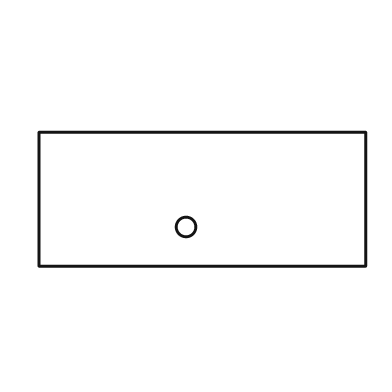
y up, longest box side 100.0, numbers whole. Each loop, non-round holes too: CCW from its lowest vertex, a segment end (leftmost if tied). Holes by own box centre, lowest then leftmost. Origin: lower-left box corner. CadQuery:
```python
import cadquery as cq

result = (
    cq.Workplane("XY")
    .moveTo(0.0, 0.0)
    .lineTo(100.0, 0.0)
    .lineTo(100.0, 41.0)
    .lineTo(0.0, 41.0)
    .close()
    .moveTo(45.0, 12.0)
    .circle(3.0)
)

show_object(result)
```